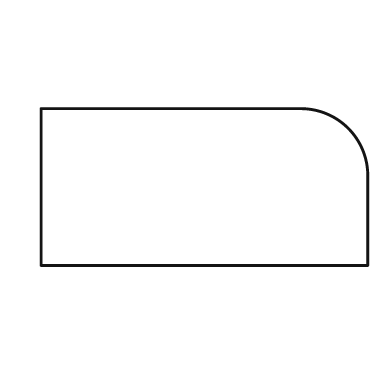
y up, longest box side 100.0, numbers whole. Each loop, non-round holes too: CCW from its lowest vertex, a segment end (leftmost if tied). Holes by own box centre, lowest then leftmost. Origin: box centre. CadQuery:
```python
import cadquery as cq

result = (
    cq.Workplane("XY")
    .moveTo(-50.0, -24.0)
    .lineTo(50.0, -24.0)
    .lineTo(50.0, 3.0)
    .threePointArc((44.0, 18.0), (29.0, 24.0))
    .lineTo(-50.0, 24.0)
    .close()
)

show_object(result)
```